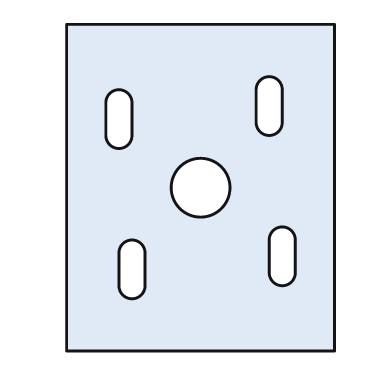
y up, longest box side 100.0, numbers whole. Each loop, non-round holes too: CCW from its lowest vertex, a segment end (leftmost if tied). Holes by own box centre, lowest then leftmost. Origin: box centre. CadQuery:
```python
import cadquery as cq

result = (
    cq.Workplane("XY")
    .moveTo(-41.0, -50.0)
    .lineTo(41.0, -50.0)
    .lineTo(41.0, 50.0)
    .lineTo(-41.0, 50.0)
    .close()
    .moveTo(-25.0, -30.0)
    .threePointArc((-21.0, -34.0), (-17.0, -30.0))
    .lineTo(-17.0, -20.0)
    .threePointArc((-21.0, -16.0), (-25.0, -20.0))
    .close()
    .moveTo(21.0, -26.0)
    .threePointArc((25.0, -30.0), (29.0, -26.0))
    .lineTo(29.0, -16.0)
    .threePointArc((25.0, -12.0), (21.0, -16.0))
    .close()
    .moveTo(0.0, 0.0)
    .circle(9.0)
    .moveTo(-29.0, 16.0)
    .threePointArc((-25.0, 12.0), (-21.0, 16.0))
    .lineTo(-21.0, 26.0)
    .threePointArc((-25.0, 30.0), (-29.0, 26.0))
    .close()
    .moveTo(17.0, 20.0)
    .threePointArc((21.0, 16.0), (25.0, 20.0))
    .lineTo(25.0, 30.0)
    .threePointArc((21.0, 34.0), (17.0, 30.0))
    .close()
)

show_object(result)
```